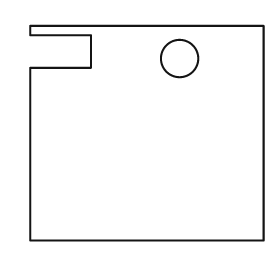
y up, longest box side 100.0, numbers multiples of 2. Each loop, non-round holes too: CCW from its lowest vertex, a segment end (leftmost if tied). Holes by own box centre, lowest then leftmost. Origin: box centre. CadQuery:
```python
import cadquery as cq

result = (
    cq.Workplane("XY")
    .moveTo(-50.0, -46.0)
    .lineTo(50.0, -46.0)
    .lineTo(50.0, 46.0)
    .lineTo(-50.0, 46.0)
    .lineTo(-50.0, 42.0)
    .lineTo(-24.0, 42.0)
    .lineTo(-24.0, 28.0)
    .lineTo(-50.0, 28.0)
    .close()
    .moveTo(14.0, 32.0)
    .circle(8.0)
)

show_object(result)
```